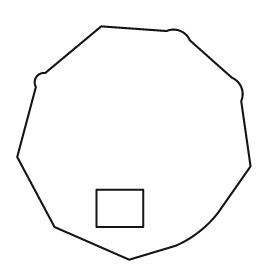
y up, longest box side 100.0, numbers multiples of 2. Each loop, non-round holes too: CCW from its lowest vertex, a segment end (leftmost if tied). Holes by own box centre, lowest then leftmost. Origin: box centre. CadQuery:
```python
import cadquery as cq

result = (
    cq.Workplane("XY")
    .moveTo(-2.0, -50.0)
    .lineTo(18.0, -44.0)
    .threePointArc((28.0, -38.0), (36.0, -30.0))
    .lineTo(50.0, -10.0)
    .lineTo(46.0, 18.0)
    .threePointArc((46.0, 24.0), (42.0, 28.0))
    .lineTo(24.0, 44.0)
    .threePointArc((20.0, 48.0), (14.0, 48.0))
    .lineTo(-14.0, 50.0)
    .lineTo(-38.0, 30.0)
    .threePointArc((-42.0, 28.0), (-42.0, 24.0))
    .lineTo(-50.0, -6.0)
    .lineTo(-34.0, -36.0)
    .close()
    .moveTo(-16.0, -36.0)
    .lineTo(4.0, -36.0)
    .lineTo(4.0, -20.0)
    .lineTo(-16.0, -20.0)
    .close()
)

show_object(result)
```